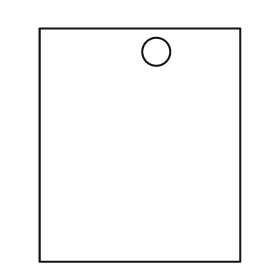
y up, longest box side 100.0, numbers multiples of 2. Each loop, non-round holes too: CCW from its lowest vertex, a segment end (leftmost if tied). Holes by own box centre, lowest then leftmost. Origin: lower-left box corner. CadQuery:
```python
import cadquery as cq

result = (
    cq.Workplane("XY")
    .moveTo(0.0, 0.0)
    .lineTo(86.0, 0.0)
    .lineTo(86.0, 100.0)
    .lineTo(0.0, 100.0)
    .close()
    .moveTo(50.0, 90.0)
    .circle(6.0)
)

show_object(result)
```